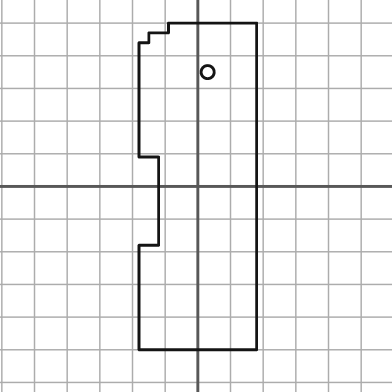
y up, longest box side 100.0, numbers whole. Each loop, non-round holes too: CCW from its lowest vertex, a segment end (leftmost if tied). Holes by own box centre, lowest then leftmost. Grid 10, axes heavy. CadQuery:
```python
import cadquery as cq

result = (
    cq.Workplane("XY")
    .moveTo(-18.0, -50.0)
    .lineTo(18.0, -50.0)
    .lineTo(18.0, 50.0)
    .lineTo(-9.0, 50.0)
    .lineTo(-9.0, 47.0)
    .lineTo(-15.0, 47.0)
    .lineTo(-15.0, 44.0)
    .lineTo(-18.0, 44.0)
    .lineTo(-18.0, 9.0)
    .lineTo(-12.0, 9.0)
    .lineTo(-12.0, -18.0)
    .lineTo(-18.0, -18.0)
    .close()
    .moveTo(3.0, 35.0)
    .circle(2.0)
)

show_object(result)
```